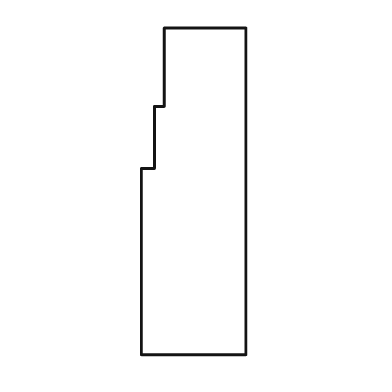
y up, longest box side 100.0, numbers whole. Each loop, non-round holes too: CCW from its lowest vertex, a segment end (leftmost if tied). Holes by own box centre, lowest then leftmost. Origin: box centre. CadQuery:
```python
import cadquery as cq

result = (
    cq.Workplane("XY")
    .moveTo(-16.0, -50.0)
    .lineTo(16.0, -50.0)
    .lineTo(16.0, 50.0)
    .lineTo(-9.0, 50.0)
    .lineTo(-9.0, 26.0)
    .lineTo(-12.0, 26.0)
    .lineTo(-12.0, 7.0)
    .lineTo(-16.0, 7.0)
    .close()
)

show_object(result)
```